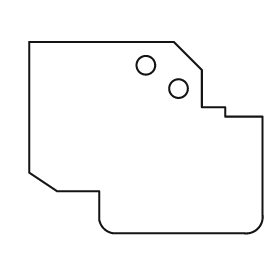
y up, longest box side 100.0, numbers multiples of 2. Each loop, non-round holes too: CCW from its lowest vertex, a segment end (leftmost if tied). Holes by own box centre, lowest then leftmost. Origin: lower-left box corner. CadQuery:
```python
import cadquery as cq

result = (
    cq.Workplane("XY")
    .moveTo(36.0, 0.0)
    .lineTo(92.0, 0.0)
    .threePointArc((98.0, 2.0), (100.0, 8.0))
    .lineTo(100.0, 50.0)
    .lineTo(84.0, 50.0)
    .lineTo(84.0, 54.0)
    .lineTo(74.0, 54.0)
    .lineTo(74.0, 70.0)
    .lineTo(62.0, 82.0)
    .lineTo(0.0, 82.0)
    .lineTo(0.0, 26.0)
    .lineTo(12.0, 18.0)
    .lineTo(30.0, 18.0)
    .lineTo(30.0, 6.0)
    .threePointArc((32.0, 2.0), (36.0, 0.0))
    .close()
    .moveTo(64.0, 62.0)
    .circle(4.0)
    .moveTo(50.0, 72.0)
    .circle(4.0)
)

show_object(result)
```